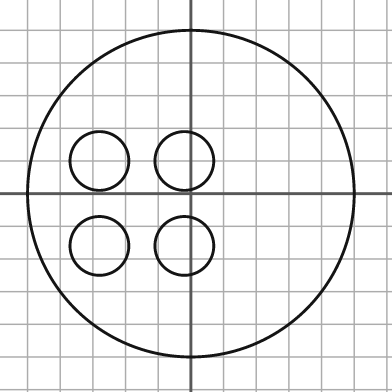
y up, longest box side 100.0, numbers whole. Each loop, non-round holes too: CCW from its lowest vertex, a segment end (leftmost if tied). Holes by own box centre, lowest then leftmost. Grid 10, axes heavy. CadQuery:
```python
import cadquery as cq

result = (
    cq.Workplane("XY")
    .moveTo(0.0, 0.0)
    .circle(50.0)
    .moveTo(-28.0, -16.0)
    .circle(9.0)
    .moveTo(-2.0, -16.0)
    .circle(9.0)
    .moveTo(-28.0, 10.0)
    .circle(9.0)
    .moveTo(-2.0, 10.0)
    .circle(9.0)
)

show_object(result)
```